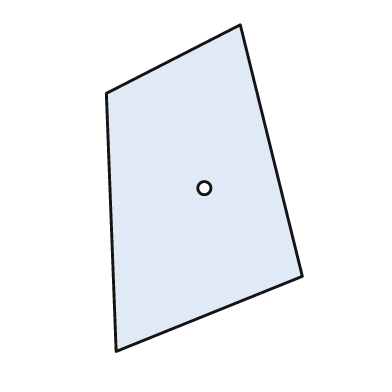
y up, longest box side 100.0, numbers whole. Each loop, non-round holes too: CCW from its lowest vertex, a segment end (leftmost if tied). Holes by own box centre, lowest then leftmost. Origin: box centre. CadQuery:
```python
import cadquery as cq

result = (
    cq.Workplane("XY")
    .moveTo(-27.0, -50.0)
    .lineTo(30.0, -27.0)
    .lineTo(11.0, 50.0)
    .lineTo(-30.0, 29.0)
    .close()
    .moveTo(0.0, 0.0)
    .circle(2.0)
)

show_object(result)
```